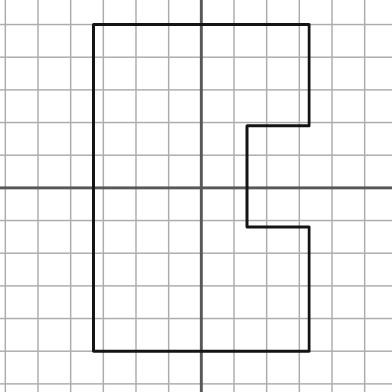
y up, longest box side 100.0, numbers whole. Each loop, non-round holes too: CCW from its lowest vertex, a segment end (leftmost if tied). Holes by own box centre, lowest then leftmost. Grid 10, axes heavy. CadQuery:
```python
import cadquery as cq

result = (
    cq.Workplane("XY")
    .moveTo(-33.0, -50.0)
    .lineTo(33.0, -50.0)
    .lineTo(33.0, -12.0)
    .lineTo(14.0, -12.0)
    .lineTo(14.0, 19.0)
    .lineTo(33.0, 19.0)
    .lineTo(33.0, 50.0)
    .lineTo(-33.0, 50.0)
    .close()
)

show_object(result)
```